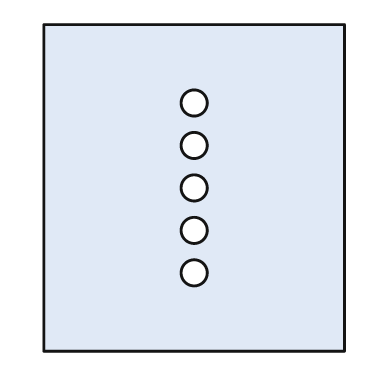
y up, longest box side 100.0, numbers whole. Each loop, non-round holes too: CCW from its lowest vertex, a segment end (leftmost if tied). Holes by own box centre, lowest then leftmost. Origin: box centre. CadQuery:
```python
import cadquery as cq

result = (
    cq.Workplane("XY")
    .moveTo(-46.0, -50.0)
    .lineTo(46.0, -50.0)
    .lineTo(46.0, 50.0)
    .lineTo(-46.0, 50.0)
    .close()
    .moveTo(0.0, -26.0)
    .circle(4.0)
    .moveTo(0.0, -13.0)
    .circle(4.0)
    .moveTo(0.0, 0.0)
    .circle(4.0)
    .moveTo(0.0, 13.0)
    .circle(4.0)
    .moveTo(0.0, 26.0)
    .circle(4.0)
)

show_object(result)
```